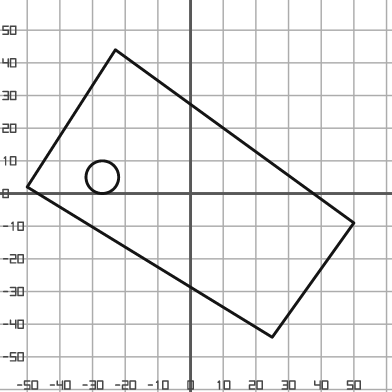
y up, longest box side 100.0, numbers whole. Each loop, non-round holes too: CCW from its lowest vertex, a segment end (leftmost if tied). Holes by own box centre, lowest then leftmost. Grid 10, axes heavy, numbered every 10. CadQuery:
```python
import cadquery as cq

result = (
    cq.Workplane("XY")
    .moveTo(25.0, -44.0)
    .lineTo(50.0, -9.0)
    .lineTo(-23.0, 44.0)
    .lineTo(-50.0, 2.0)
    .close()
    .moveTo(-27.0, 5.0)
    .circle(5.0)
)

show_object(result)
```